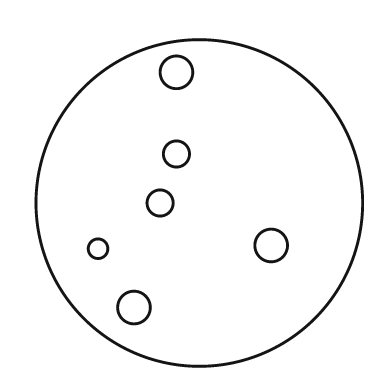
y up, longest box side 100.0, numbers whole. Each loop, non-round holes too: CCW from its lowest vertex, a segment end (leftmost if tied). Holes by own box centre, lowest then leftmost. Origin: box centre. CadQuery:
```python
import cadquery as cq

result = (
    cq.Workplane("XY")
    .moveTo(0.0, 0.0)
    .circle(50.0)
    .moveTo(-20.0, -32.0)
    .circle(5.0)
    .moveTo(-31.0, -14.0)
    .circle(3.0)
    .moveTo(22.0, -13.0)
    .circle(5.0)
    .moveTo(-12.0, 0.0)
    .circle(4.0)
    .moveTo(-7.0, 15.0)
    .circle(4.0)
    .moveTo(-7.0, 40.0)
    .circle(5.0)
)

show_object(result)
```